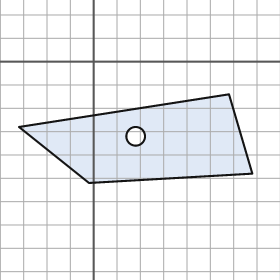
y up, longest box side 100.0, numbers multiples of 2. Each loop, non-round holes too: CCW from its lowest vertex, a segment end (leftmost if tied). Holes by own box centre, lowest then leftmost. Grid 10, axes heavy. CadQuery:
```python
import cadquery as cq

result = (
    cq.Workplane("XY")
    .moveTo(-2.0, -52.0)
    .lineTo(68.0, -48.0)
    .lineTo(58.0, -14.0)
    .lineTo(-32.0, -28.0)
    .close()
    .moveTo(18.0, -32.0)
    .circle(4.0)
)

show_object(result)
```